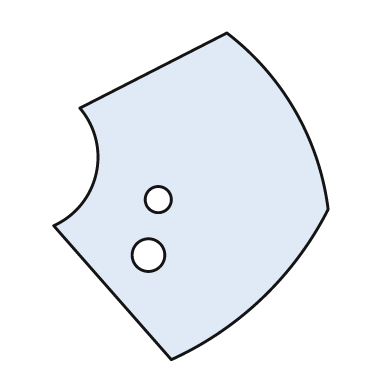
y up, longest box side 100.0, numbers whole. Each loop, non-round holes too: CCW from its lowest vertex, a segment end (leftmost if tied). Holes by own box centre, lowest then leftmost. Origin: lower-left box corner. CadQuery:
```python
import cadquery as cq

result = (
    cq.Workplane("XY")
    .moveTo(36.0, 0.0)
    .threePointArc((64.0, 19.0), (84.0, 46.0))
    .threePointArc((74.0, 76.0), (53.0, 100.0))
    .lineTo(8.0, 77.0)
    .threePointArc((13.0, 57.0), (0.0, 41.0))
    .close()
    .moveTo(29.0, 32.0)
    .circle(5.0)
    .moveTo(32.0, 49.0)
    .circle(4.0)
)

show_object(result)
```